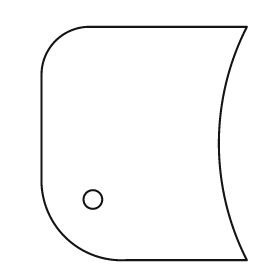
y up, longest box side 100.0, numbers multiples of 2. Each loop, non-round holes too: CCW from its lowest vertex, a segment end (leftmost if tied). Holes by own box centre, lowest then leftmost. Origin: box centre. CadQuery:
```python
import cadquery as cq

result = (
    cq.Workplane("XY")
    .moveTo(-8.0, -50.0)
    .lineTo(44.0, -50.0)
    .threePointArc((32.0, 0.0), (44.0, 50.0))
    .lineTo(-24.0, 50.0)
    .threePointArc((-38.0, 44.0), (-44.0, 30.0))
    .lineTo(-44.0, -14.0)
    .threePointArc((-34.0, -40.0), (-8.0, -50.0))
    .close()
    .moveTo(-22.0, -24.0)
    .circle(4.0)
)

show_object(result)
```